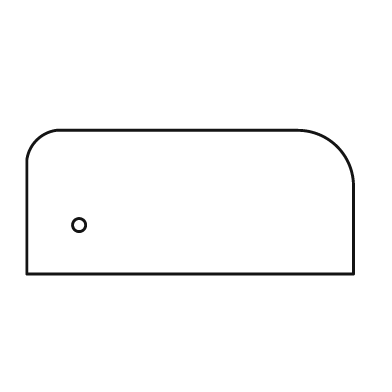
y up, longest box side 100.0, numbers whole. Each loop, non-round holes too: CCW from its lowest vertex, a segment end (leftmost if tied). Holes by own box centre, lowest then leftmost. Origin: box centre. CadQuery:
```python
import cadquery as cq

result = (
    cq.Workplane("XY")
    .moveTo(-50.0, -22.0)
    .lineTo(50.0, -22.0)
    .lineTo(50.0, 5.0)
    .threePointArc((45.0, 17.0), (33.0, 22.0))
    .lineTo(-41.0, 22.0)
    .threePointArc((-47.0, 19.0), (-50.0, 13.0))
    .close()
    .moveTo(-34.0, -7.0)
    .circle(2.0)
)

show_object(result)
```